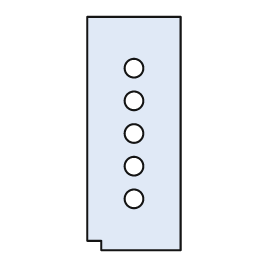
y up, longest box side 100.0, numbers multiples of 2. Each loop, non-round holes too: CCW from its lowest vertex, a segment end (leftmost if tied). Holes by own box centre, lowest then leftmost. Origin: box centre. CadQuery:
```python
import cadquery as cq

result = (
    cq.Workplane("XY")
    .moveTo(-14.0, -50.0)
    .lineTo(20.0, -50.0)
    .lineTo(20.0, 50.0)
    .lineTo(-20.0, 50.0)
    .lineTo(-20.0, -46.0)
    .lineTo(-14.0, -46.0)
    .close()
    .moveTo(0.0, -28.0)
    .circle(4.0)
    .moveTo(0.0, -14.0)
    .circle(4.0)
    .moveTo(0.0, 0.0)
    .circle(4.0)
    .moveTo(0.0, 14.0)
    .circle(4.0)
    .moveTo(0.0, 28.0)
    .circle(4.0)
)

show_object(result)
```